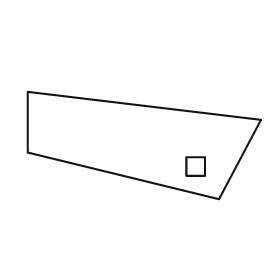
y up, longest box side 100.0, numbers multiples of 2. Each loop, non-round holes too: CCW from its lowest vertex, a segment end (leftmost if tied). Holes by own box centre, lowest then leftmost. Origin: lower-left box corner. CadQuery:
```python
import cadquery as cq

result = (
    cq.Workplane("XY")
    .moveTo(82.0, 0.0)
    .lineTo(100.0, 34.0)
    .lineTo(0.0, 46.0)
    .lineTo(0.0, 20.0)
    .close()
    .moveTo(68.0, 10.0)
    .lineTo(76.0, 10.0)
    .lineTo(76.0, 18.0)
    .lineTo(68.0, 18.0)
    .close()
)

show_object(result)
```